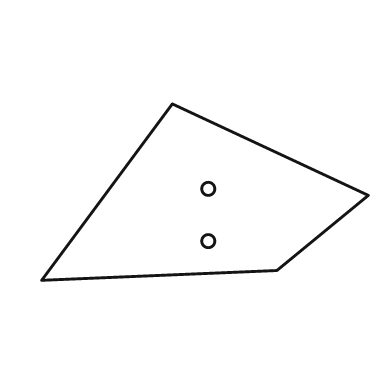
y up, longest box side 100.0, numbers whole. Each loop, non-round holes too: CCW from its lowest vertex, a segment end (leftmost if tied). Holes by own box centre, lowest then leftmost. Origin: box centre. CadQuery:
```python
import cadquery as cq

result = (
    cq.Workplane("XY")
    .moveTo(-50.0, -27.0)
    .lineTo(22.0, -24.0)
    .lineTo(50.0, -1.0)
    .lineTo(-10.0, 27.0)
    .close()
    .moveTo(1.0, -15.0)
    .circle(2.0)
    .moveTo(1.0, 1.0)
    .circle(2.0)
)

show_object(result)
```